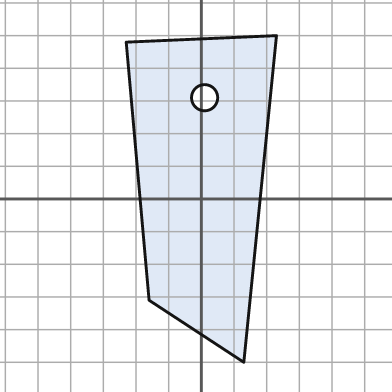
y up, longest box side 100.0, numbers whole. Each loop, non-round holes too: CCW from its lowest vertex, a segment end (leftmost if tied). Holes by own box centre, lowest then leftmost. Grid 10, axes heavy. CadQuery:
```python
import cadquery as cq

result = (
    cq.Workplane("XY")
    .moveTo(13.0, -50.0)
    .lineTo(23.0, 50.0)
    .lineTo(-23.0, 48.0)
    .lineTo(-16.0, -31.0)
    .close()
    .moveTo(1.0, 31.0)
    .circle(4.0)
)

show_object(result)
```